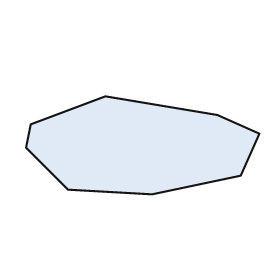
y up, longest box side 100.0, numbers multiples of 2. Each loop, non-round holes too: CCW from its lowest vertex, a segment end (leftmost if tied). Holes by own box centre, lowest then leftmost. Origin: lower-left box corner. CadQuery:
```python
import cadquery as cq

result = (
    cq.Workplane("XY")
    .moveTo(54.0, 0.0)
    .lineTo(92.0, 8.0)
    .lineTo(100.0, 26.0)
    .lineTo(82.0, 34.0)
    .lineTo(34.0, 42.0)
    .lineTo(2.0, 30.0)
    .lineTo(0.0, 20.0)
    .lineTo(18.0, 2.0)
    .close()
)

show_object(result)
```